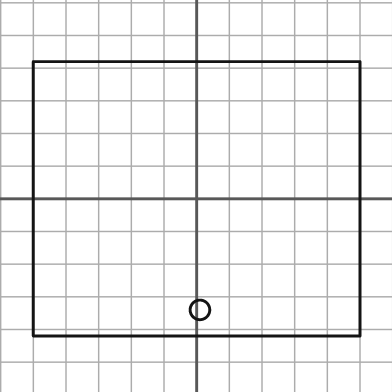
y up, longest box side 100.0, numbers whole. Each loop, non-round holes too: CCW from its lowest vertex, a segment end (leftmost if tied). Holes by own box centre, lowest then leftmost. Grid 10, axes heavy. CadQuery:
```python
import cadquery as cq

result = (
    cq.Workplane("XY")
    .moveTo(-50.0, -42.0)
    .lineTo(50.0, -42.0)
    .lineTo(50.0, 42.0)
    .lineTo(-50.0, 42.0)
    .close()
    .moveTo(1.0, -34.0)
    .circle(3.0)
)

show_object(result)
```